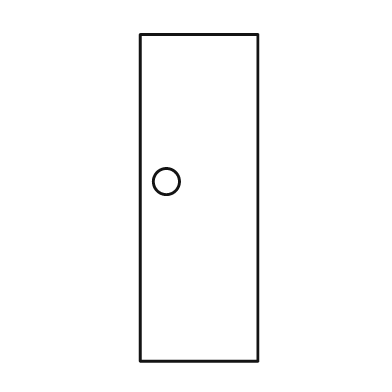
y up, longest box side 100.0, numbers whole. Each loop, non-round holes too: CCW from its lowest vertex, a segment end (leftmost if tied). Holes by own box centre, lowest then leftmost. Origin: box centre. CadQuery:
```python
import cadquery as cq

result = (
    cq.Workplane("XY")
    .moveTo(-18.0, -50.0)
    .lineTo(18.0, -50.0)
    .lineTo(18.0, 50.0)
    .lineTo(-18.0, 50.0)
    .close()
    .moveTo(-10.0, 5.0)
    .circle(4.0)
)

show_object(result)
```